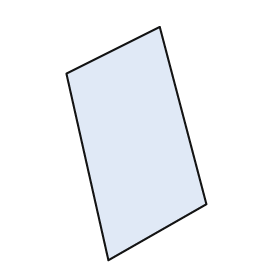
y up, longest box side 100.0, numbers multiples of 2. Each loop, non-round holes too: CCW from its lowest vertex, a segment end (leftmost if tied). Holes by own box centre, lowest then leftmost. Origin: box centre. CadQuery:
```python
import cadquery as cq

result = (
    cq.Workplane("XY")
    .moveTo(-12.0, -50.0)
    .lineTo(30.0, -26.0)
    .lineTo(10.0, 50.0)
    .lineTo(-30.0, 30.0)
    .close()
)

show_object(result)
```